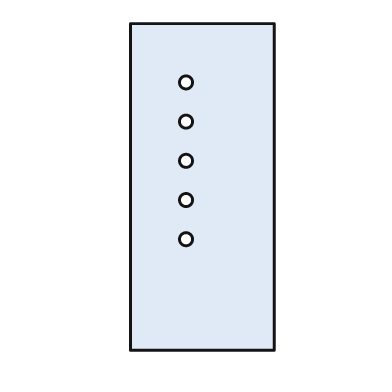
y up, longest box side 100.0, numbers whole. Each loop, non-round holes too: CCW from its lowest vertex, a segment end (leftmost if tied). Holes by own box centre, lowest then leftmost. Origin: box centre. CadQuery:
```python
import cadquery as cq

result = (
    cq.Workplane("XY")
    .moveTo(-22.0, -50.0)
    .lineTo(22.0, -50.0)
    .lineTo(22.0, 50.0)
    .lineTo(-22.0, 50.0)
    .close()
    .moveTo(-5.0, -16.0)
    .circle(2.0)
    .moveTo(-5.0, -4.0)
    .circle(2.0)
    .moveTo(-5.0, 8.0)
    .circle(2.0)
    .moveTo(-5.0, 20.0)
    .circle(2.0)
    .moveTo(-5.0, 32.0)
    .circle(2.0)
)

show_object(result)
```